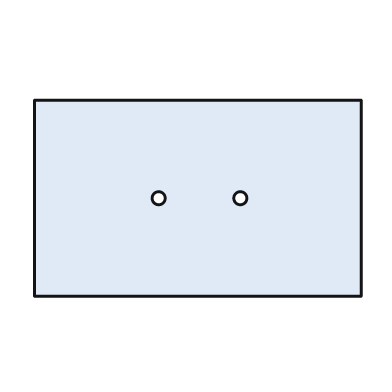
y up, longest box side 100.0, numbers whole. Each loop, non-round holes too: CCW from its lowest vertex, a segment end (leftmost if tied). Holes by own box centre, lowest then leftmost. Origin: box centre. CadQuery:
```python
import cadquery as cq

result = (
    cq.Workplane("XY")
    .moveTo(-50.0, -30.0)
    .lineTo(50.0, -30.0)
    .lineTo(50.0, 30.0)
    .lineTo(-50.0, 30.0)
    .close()
    .moveTo(-12.0, 0.0)
    .circle(2.0)
    .moveTo(13.0, 0.0)
    .circle(2.0)
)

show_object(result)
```